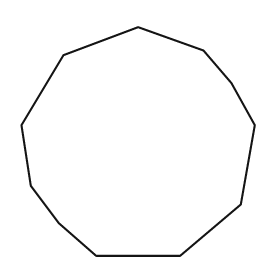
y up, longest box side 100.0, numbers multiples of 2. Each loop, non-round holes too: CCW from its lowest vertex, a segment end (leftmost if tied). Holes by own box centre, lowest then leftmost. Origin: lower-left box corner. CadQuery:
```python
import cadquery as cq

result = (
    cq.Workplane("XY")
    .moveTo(32.0, 0.0)
    .lineTo(68.0, 0.0)
    .lineTo(94.0, 22.0)
    .lineTo(100.0, 56.0)
    .lineTo(90.0, 74.0)
    .lineTo(78.0, 88.0)
    .lineTo(50.0, 98.0)
    .lineTo(18.0, 86.0)
    .lineTo(0.0, 56.0)
    .lineTo(4.0, 30.0)
    .lineTo(16.0, 14.0)
    .close()
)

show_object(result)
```